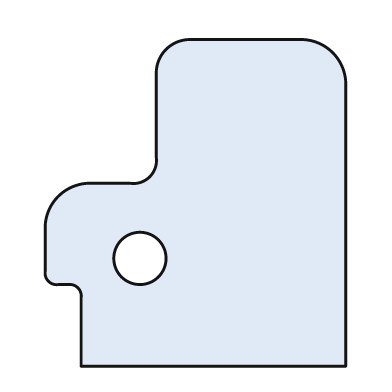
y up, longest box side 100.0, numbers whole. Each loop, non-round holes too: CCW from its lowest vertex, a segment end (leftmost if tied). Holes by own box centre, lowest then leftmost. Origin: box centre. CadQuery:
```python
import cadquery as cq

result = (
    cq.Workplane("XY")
    .moveTo(-35.0, -50.0)
    .lineTo(46.0, -50.0)
    .lineTo(46.0, 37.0)
    .threePointArc((42.0, 46.0), (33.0, 50.0))
    .lineTo(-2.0, 50.0)
    .threePointArc((-9.0, 47.0), (-12.0, 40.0))
    .lineTo(-12.0, 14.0)
    .threePointArc((-14.0, 8.0), (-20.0, 6.0))
    .lineTo(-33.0, 6.0)
    .threePointArc((-42.0, 2.0), (-46.0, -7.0))
    .lineTo(-46.0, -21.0)
    .threePointArc((-45.0, -24.0), (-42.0, -25.0))
    .lineTo(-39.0, -25.0)
    .threePointArc((-36.0, -26.0), (-35.0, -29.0))
    .close()
    .moveTo(-17.0, -17.0)
    .circle(8.0)
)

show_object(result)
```